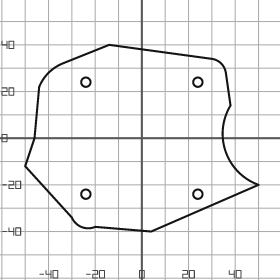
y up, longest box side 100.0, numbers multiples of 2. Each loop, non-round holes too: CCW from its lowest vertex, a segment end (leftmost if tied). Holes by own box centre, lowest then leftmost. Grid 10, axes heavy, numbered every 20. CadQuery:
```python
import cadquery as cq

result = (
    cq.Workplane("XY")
    .moveTo(4.0, -40.0)
    .lineTo(50.0, -20.0)
    .threePointArc((36.0, -6.0), (38.0, 14.0))
    .lineTo(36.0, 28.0)
    .threePointArc((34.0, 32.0), (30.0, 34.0))
    .lineTo(-14.0, 40.0)
    .lineTo(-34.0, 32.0)
    .threePointArc((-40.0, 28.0), (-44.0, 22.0))
    .lineTo(-46.0, 0.0)
    .lineTo(-50.0, -12.0)
    .lineTo(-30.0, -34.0)
    .threePointArc((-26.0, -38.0), (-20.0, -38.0))
    .close()
    .moveTo(-24.0, -24.0)
    .circle(2.0)
    .moveTo(24.0, -24.0)
    .circle(2.0)
    .moveTo(-24.0, 24.0)
    .circle(2.0)
    .moveTo(24.0, 24.0)
    .circle(2.0)
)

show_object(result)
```